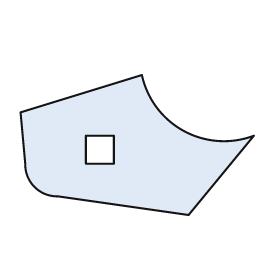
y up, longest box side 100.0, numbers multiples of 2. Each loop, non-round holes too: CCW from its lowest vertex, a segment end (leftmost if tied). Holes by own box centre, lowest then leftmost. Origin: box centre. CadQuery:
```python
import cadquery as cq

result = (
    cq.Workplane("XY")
    .moveTo(22.0, -30.0)
    .lineTo(50.0, 4.0)
    .threePointArc((20.0, 6.0), (2.0, 30.0))
    .lineTo(-50.0, 14.0)
    .lineTo(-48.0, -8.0)
    .threePointArc((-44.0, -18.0), (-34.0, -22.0))
    .close()
    .moveTo(-22.0, -8.0)
    .lineTo(-10.0, -8.0)
    .lineTo(-10.0, 4.0)
    .lineTo(-22.0, 4.0)
    .close()
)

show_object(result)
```